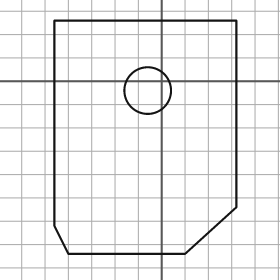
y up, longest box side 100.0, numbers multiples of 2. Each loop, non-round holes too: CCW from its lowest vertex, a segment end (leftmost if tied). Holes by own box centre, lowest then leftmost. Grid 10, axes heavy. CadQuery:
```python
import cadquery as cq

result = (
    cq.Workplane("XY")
    .moveTo(-40.0, -74.0)
    .lineTo(10.0, -74.0)
    .lineTo(32.0, -54.0)
    .lineTo(32.0, 26.0)
    .lineTo(-46.0, 26.0)
    .lineTo(-46.0, -62.0)
    .close()
    .moveTo(-6.0, -4.0)
    .circle(10.0)
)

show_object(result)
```